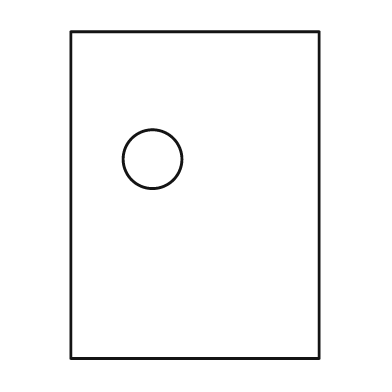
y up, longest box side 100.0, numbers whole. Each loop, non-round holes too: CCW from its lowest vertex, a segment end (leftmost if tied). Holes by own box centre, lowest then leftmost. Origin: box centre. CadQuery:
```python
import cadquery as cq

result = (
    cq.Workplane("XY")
    .moveTo(-38.0, -50.0)
    .lineTo(38.0, -50.0)
    .lineTo(38.0, 50.0)
    .lineTo(-38.0, 50.0)
    .close()
    .moveTo(-13.0, 11.0)
    .circle(9.0)
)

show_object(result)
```